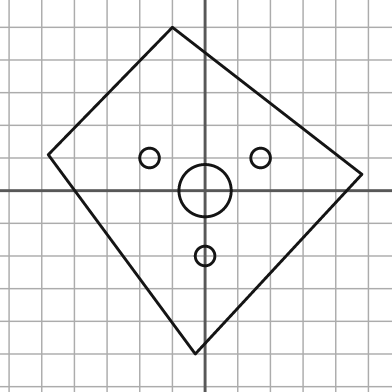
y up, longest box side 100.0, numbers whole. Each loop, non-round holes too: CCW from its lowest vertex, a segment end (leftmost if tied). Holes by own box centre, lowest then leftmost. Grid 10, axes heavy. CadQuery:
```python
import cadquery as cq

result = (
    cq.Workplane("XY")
    .moveTo(-3.0, -50.0)
    .lineTo(48.0, 5.0)
    .lineTo(-10.0, 50.0)
    .lineTo(-48.0, 11.0)
    .close()
    .moveTo(0.0, -20.0)
    .circle(3.0)
    .moveTo(0.0, 0.0)
    .circle(8.0)
    .moveTo(-17.0, 10.0)
    .circle(3.0)
    .moveTo(17.0, 10.0)
    .circle(3.0)
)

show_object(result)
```